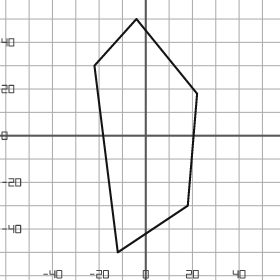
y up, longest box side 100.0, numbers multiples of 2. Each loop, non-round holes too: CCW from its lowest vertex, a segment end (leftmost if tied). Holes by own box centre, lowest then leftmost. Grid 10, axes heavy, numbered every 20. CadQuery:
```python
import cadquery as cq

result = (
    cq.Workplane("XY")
    .moveTo(-12.0, -50.0)
    .lineTo(18.0, -30.0)
    .lineTo(22.0, 18.0)
    .lineTo(-4.0, 50.0)
    .lineTo(-22.0, 30.0)
    .close()
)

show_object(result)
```